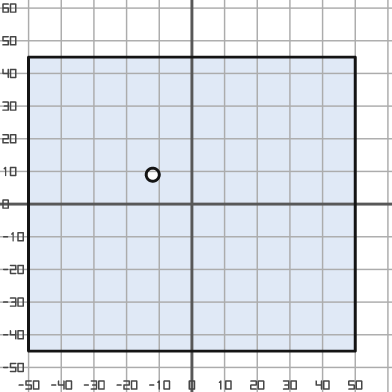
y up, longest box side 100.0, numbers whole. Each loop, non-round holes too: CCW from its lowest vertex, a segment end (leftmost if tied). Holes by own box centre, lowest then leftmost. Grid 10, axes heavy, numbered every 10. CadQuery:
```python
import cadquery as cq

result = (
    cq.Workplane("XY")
    .moveTo(-50.0, -45.0)
    .lineTo(50.0, -45.0)
    .lineTo(50.0, 45.0)
    .lineTo(-50.0, 45.0)
    .close()
    .moveTo(-12.0, 9.0)
    .circle(2.0)
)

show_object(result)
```